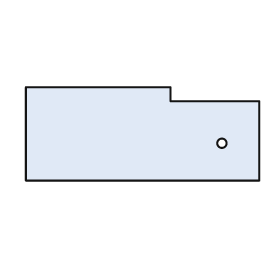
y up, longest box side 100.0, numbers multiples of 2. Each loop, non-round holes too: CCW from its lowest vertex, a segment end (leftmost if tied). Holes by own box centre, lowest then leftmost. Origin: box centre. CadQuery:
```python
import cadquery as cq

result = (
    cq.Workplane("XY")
    .moveTo(-50.0, -20.0)
    .lineTo(50.0, -20.0)
    .lineTo(50.0, 14.0)
    .lineTo(12.0, 14.0)
    .lineTo(12.0, 20.0)
    .lineTo(-50.0, 20.0)
    .close()
    .moveTo(34.0, -4.0)
    .circle(2.0)
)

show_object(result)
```